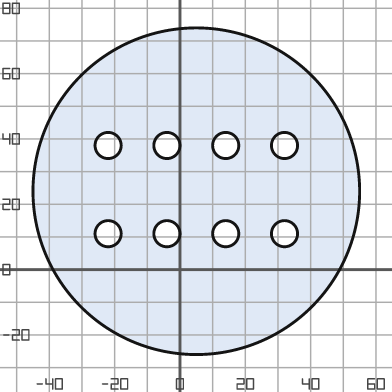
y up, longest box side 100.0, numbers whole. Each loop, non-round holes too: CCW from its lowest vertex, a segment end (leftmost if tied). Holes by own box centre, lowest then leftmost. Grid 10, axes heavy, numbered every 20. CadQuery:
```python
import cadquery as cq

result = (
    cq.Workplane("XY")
    .moveTo(5.0, 24.0)
    .circle(50.0)
    .moveTo(-22.0, 11.0)
    .circle(4.0)
    .moveTo(-4.0, 11.0)
    .circle(4.0)
    .moveTo(14.0, 11.0)
    .circle(4.0)
    .moveTo(32.0, 11.0)
    .circle(4.0)
    .moveTo(-22.0, 38.0)
    .circle(4.0)
    .moveTo(-4.0, 38.0)
    .circle(4.0)
    .moveTo(14.0, 38.0)
    .circle(4.0)
    .moveTo(32.0, 38.0)
    .circle(4.0)
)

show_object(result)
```